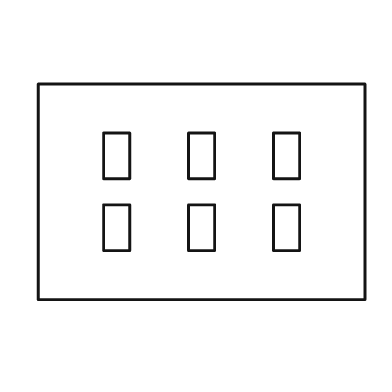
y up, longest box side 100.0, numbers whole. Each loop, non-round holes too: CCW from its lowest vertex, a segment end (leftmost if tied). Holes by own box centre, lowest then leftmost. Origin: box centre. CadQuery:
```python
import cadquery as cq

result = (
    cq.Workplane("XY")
    .moveTo(-50.0, -33.0)
    .lineTo(50.0, -33.0)
    .lineTo(50.0, 33.0)
    .lineTo(-50.0, 33.0)
    .close()
    .moveTo(-30.0, -18.0)
    .lineTo(-22.0, -18.0)
    .lineTo(-22.0, -4.0)
    .lineTo(-30.0, -4.0)
    .close()
    .moveTo(-4.0, -18.0)
    .lineTo(4.0, -18.0)
    .lineTo(4.0, -4.0)
    .lineTo(-4.0, -4.0)
    .close()
    .moveTo(22.0, -18.0)
    .lineTo(30.0, -18.0)
    .lineTo(30.0, -4.0)
    .lineTo(22.0, -4.0)
    .close()
    .moveTo(-30.0, 4.0)
    .lineTo(-22.0, 4.0)
    .lineTo(-22.0, 18.0)
    .lineTo(-30.0, 18.0)
    .close()
    .moveTo(-4.0, 4.0)
    .lineTo(4.0, 4.0)
    .lineTo(4.0, 18.0)
    .lineTo(-4.0, 18.0)
    .close()
    .moveTo(22.0, 4.0)
    .lineTo(30.0, 4.0)
    .lineTo(30.0, 18.0)
    .lineTo(22.0, 18.0)
    .close()
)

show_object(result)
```